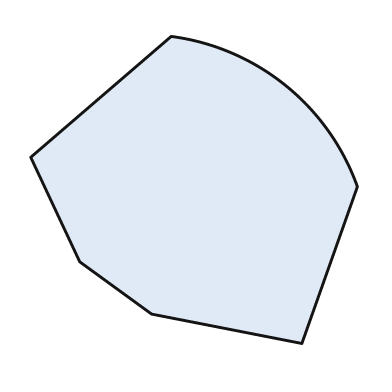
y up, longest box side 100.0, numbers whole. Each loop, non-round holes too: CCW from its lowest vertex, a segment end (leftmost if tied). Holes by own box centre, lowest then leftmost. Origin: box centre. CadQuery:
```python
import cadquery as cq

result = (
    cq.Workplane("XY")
    .moveTo(33.0, -47.0)
    .lineTo(50.0, 1.0)
    .threePointArc((28.0, 32.0), (-7.0, 47.0))
    .lineTo(-50.0, 10.0)
    .lineTo(-35.0, -22.0)
    .lineTo(-13.0, -38.0)
    .close()
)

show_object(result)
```